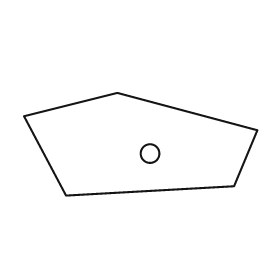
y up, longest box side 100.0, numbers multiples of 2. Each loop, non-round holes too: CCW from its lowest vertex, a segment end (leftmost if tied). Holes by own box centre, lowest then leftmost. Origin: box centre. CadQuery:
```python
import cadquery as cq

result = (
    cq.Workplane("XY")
    .moveTo(-32.0, -22.0)
    .lineTo(40.0, -18.0)
    .lineTo(50.0, 6.0)
    .lineTo(-10.0, 22.0)
    .lineTo(-50.0, 12.0)
    .close()
    .moveTo(4.0, -4.0)
    .circle(4.0)
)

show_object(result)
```